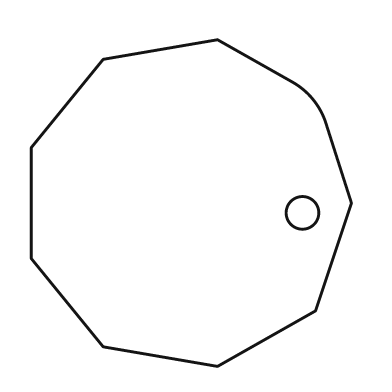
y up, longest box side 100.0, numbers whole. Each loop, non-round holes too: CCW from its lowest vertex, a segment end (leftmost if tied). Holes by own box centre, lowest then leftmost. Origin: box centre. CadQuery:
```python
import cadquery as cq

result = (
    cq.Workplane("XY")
    .moveTo(8.0, -50.0)
    .lineTo(38.0, -33.0)
    .lineTo(49.0, 0.0)
    .lineTo(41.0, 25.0)
    .threePointArc((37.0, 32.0), (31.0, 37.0))
    .lineTo(8.0, 50.0)
    .lineTo(-27.0, 44.0)
    .lineTo(-49.0, 17.0)
    .lineTo(-49.0, -17.0)
    .lineTo(-27.0, -44.0)
    .close()
    .moveTo(34.0, -3.0)
    .circle(5.0)
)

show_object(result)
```